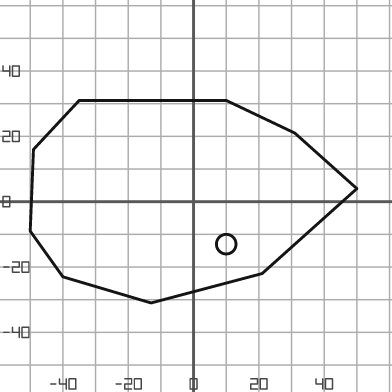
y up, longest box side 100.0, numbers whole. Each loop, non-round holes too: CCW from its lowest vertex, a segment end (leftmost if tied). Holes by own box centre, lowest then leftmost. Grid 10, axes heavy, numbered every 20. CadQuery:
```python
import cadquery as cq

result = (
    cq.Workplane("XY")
    .moveTo(-13.0, -31.0)
    .lineTo(21.0, -22.0)
    .lineTo(50.0, 4.0)
    .lineTo(31.0, 21.0)
    .lineTo(10.0, 31.0)
    .lineTo(-35.0, 31.0)
    .lineTo(-49.0, 16.0)
    .lineTo(-50.0, -9.0)
    .lineTo(-40.0, -23.0)
    .close()
    .moveTo(10.0, -13.0)
    .circle(3.0)
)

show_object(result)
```